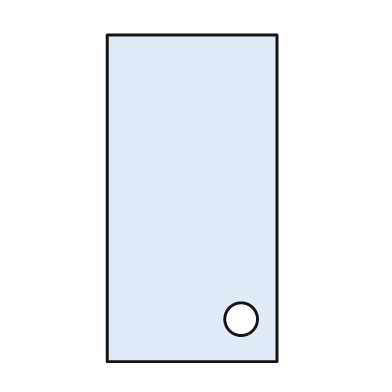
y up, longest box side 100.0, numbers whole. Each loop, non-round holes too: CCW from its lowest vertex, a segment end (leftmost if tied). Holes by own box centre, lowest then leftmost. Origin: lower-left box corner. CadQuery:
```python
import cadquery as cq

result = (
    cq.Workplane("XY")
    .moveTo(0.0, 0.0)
    .lineTo(52.0, 0.0)
    .lineTo(52.0, 100.0)
    .lineTo(0.0, 100.0)
    .close()
    .moveTo(41.0, 13.0)
    .circle(5.0)
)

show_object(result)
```